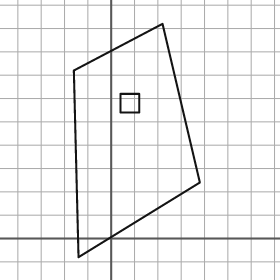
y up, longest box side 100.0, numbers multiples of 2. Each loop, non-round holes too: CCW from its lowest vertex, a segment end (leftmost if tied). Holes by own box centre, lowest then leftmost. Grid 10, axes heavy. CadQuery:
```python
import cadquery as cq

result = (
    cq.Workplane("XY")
    .moveTo(-14.0, -8.0)
    .lineTo(38.0, 24.0)
    .lineTo(22.0, 92.0)
    .lineTo(-16.0, 72.0)
    .close()
    .moveTo(4.0, 54.0)
    .lineTo(12.0, 54.0)
    .lineTo(12.0, 62.0)
    .lineTo(4.0, 62.0)
    .close()
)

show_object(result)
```